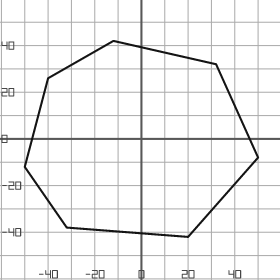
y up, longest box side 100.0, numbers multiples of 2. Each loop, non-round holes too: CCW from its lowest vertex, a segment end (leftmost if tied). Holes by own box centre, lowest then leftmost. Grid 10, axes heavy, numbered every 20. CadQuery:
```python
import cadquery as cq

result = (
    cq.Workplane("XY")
    .moveTo(20.0, -42.0)
    .lineTo(50.0, -8.0)
    .lineTo(32.0, 32.0)
    .lineTo(-12.0, 42.0)
    .lineTo(-40.0, 26.0)
    .lineTo(-50.0, -12.0)
    .lineTo(-32.0, -38.0)
    .close()
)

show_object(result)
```